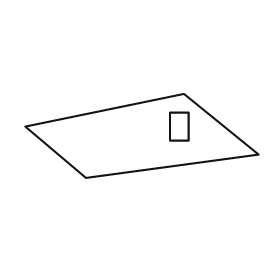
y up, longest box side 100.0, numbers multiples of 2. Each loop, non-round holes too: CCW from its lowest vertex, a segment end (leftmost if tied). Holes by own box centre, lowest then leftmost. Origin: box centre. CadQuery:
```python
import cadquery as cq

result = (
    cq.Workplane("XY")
    .moveTo(-24.0, -18.0)
    .lineTo(50.0, -8.0)
    .lineTo(18.0, 18.0)
    .lineTo(-50.0, 4.0)
    .close()
    .moveTo(12.0, -2.0)
    .lineTo(20.0, -2.0)
    .lineTo(20.0, 10.0)
    .lineTo(12.0, 10.0)
    .close()
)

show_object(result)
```